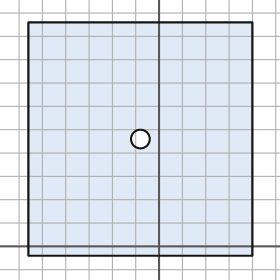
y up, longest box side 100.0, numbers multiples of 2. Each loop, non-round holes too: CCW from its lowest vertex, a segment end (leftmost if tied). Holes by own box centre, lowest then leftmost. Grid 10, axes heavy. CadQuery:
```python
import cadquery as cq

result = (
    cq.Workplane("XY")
    .moveTo(-56.0, -4.0)
    .lineTo(40.0, -4.0)
    .lineTo(40.0, 96.0)
    .lineTo(-56.0, 96.0)
    .close()
    .moveTo(-8.0, 46.0)
    .circle(4.0)
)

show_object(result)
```